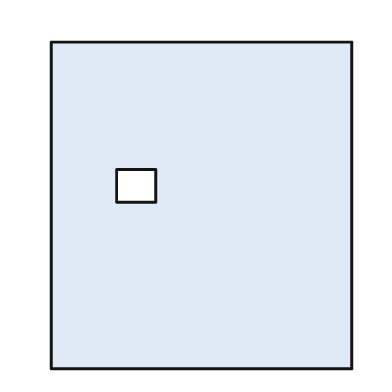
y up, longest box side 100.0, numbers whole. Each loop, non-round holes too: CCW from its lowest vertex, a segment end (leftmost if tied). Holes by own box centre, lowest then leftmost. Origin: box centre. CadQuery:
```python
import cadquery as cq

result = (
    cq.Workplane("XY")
    .moveTo(-46.0, -50.0)
    .lineTo(46.0, -50.0)
    .lineTo(46.0, 50.0)
    .lineTo(-46.0, 50.0)
    .close()
    .moveTo(-26.0, 1.0)
    .lineTo(-14.0, 1.0)
    .lineTo(-14.0, 11.0)
    .lineTo(-26.0, 11.0)
    .close()
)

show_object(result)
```